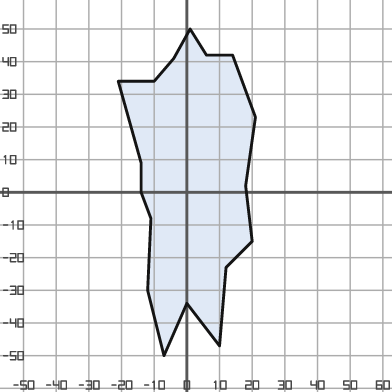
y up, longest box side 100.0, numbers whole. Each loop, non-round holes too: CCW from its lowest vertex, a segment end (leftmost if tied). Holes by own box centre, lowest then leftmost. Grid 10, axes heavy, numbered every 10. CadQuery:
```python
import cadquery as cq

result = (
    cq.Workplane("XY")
    .moveTo(-7.0, -50.0)
    .lineTo(0.0, -34.0)
    .lineTo(10.0, -47.0)
    .lineTo(12.0, -23.0)
    .lineTo(20.0, -15.0)
    .lineTo(18.0, 2.0)
    .lineTo(21.0, 23.0)
    .lineTo(14.0, 42.0)
    .lineTo(6.0, 42.0)
    .lineTo(1.0, 50.0)
    .lineTo(-4.0, 41.0)
    .lineTo(-10.0, 34.0)
    .lineTo(-21.0, 34.0)
    .lineTo(-14.0, 9.0)
    .lineTo(-14.0, 0.0)
    .lineTo(-11.0, -8.0)
    .lineTo(-12.0, -30.0)
    .close()
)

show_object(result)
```